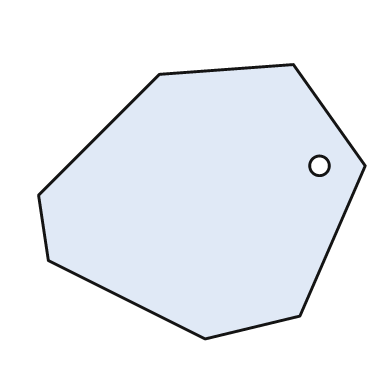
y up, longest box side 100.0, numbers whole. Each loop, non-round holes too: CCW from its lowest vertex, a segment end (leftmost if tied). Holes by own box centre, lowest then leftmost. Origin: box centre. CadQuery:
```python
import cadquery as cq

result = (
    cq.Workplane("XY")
    .moveTo(1.0, -42.0)
    .lineTo(30.0, -35.0)
    .lineTo(50.0, 11.0)
    .lineTo(28.0, 42.0)
    .lineTo(-13.0, 39.0)
    .lineTo(-50.0, 2.0)
    .lineTo(-47.0, -18.0)
    .close()
    .moveTo(36.0, 11.0)
    .circle(3.0)
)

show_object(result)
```